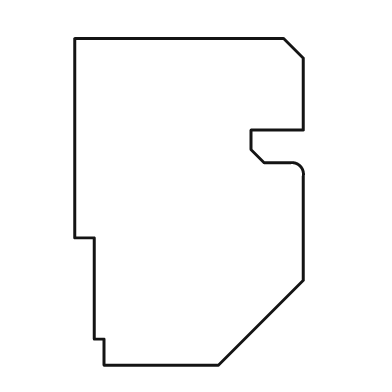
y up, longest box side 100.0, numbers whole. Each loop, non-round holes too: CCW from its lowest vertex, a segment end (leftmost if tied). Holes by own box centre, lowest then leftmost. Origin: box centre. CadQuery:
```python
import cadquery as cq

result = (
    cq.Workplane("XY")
    .moveTo(-26.0, -50.0)
    .lineTo(9.0, -50.0)
    .lineTo(35.0, -24.0)
    .lineTo(35.0, 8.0)
    .threePointArc((34.0, 11.0), (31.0, 12.0))
    .lineTo(23.0, 12.0)
    .lineTo(19.0, 16.0)
    .lineTo(19.0, 22.0)
    .lineTo(35.0, 22.0)
    .lineTo(35.0, 44.0)
    .lineTo(29.0, 50.0)
    .lineTo(-35.0, 50.0)
    .lineTo(-35.0, -11.0)
    .lineTo(-29.0, -11.0)
    .lineTo(-29.0, -42.0)
    .lineTo(-26.0, -42.0)
    .close()
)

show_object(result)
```